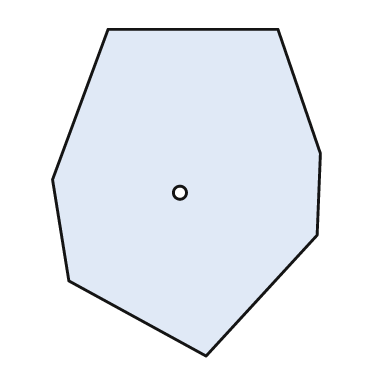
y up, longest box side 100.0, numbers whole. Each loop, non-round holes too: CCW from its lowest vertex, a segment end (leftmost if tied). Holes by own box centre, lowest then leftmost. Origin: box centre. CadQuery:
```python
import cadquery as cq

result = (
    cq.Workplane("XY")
    .moveTo(6.0, -50.0)
    .lineTo(40.0, -13.0)
    .lineTo(41.0, 12.0)
    .lineTo(28.0, 50.0)
    .lineTo(-24.0, 50.0)
    .lineTo(-41.0, 4.0)
    .lineTo(-36.0, -27.0)
    .close()
    .moveTo(-2.0, 0.0)
    .circle(2.0)
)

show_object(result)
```